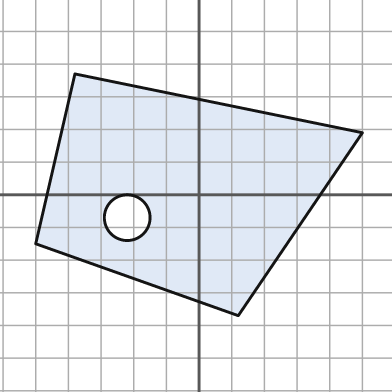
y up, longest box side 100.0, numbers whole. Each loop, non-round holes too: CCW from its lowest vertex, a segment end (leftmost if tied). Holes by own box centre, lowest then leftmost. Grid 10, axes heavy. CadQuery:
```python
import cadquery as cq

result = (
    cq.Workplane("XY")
    .moveTo(12.0, -37.0)
    .lineTo(50.0, 19.0)
    .lineTo(-38.0, 37.0)
    .lineTo(-50.0, -15.0)
    .close()
    .moveTo(-22.0, -7.0)
    .circle(7.0)
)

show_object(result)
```